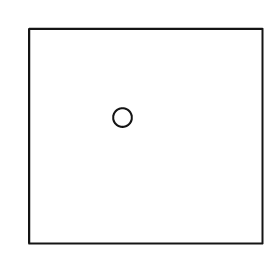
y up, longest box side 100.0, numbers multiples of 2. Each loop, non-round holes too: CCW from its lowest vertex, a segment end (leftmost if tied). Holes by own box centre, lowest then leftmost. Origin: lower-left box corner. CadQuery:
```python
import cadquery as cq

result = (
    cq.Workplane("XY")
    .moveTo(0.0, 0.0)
    .lineTo(100.0, 0.0)
    .lineTo(100.0, 92.0)
    .lineTo(0.0, 92.0)
    .close()
    .moveTo(40.0, 54.0)
    .circle(4.0)
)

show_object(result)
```